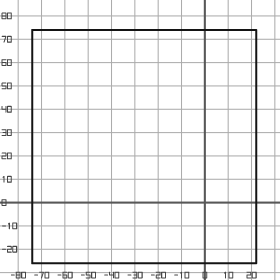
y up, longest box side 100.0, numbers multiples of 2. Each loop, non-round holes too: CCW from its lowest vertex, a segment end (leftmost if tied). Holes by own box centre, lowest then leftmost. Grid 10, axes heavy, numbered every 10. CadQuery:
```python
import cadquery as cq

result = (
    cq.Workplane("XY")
    .moveTo(-74.0, -26.0)
    .lineTo(22.0, -26.0)
    .lineTo(22.0, 74.0)
    .lineTo(-74.0, 74.0)
    .close()
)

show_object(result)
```